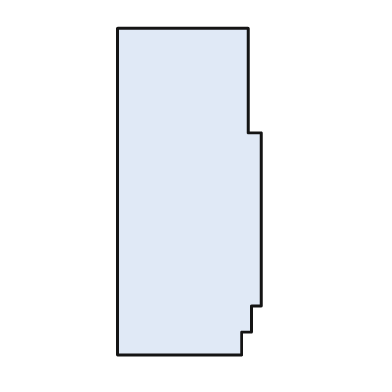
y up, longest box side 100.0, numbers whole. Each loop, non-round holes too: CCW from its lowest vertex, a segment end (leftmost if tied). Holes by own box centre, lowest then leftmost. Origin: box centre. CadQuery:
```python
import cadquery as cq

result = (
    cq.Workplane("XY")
    .moveTo(-22.0, -50.0)
    .lineTo(16.0, -50.0)
    .lineTo(16.0, -43.0)
    .lineTo(19.0, -43.0)
    .lineTo(19.0, -35.0)
    .lineTo(22.0, -35.0)
    .lineTo(22.0, 18.0)
    .lineTo(18.0, 18.0)
    .lineTo(18.0, 50.0)
    .lineTo(-22.0, 50.0)
    .close()
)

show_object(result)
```